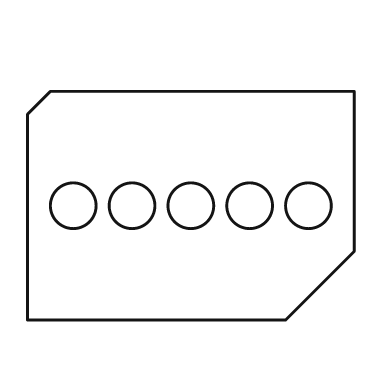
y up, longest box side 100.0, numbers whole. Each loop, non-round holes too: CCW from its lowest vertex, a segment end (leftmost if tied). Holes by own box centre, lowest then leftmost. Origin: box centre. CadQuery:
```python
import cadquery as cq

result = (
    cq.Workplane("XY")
    .moveTo(-50.0, -35.0)
    .lineTo(29.0, -35.0)
    .lineTo(50.0, -14.0)
    .lineTo(50.0, 35.0)
    .lineTo(-43.0, 35.0)
    .lineTo(-50.0, 28.0)
    .close()
    .moveTo(-36.0, 0.0)
    .circle(7.0)
    .moveTo(-18.0, 0.0)
    .circle(7.0)
    .moveTo(0.0, 0.0)
    .circle(7.0)
    .moveTo(18.0, 0.0)
    .circle(7.0)
    .moveTo(36.0, 0.0)
    .circle(7.0)
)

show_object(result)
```